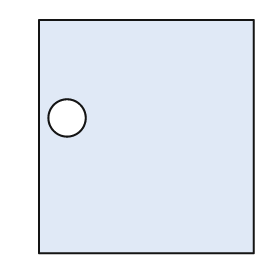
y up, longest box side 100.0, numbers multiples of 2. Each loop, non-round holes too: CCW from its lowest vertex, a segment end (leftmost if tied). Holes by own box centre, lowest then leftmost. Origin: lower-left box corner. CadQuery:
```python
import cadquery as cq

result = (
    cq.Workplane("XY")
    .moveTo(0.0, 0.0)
    .lineTo(92.0, 0.0)
    .lineTo(92.0, 100.0)
    .lineTo(0.0, 100.0)
    .close()
    .moveTo(12.0, 58.0)
    .circle(8.0)
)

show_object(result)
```